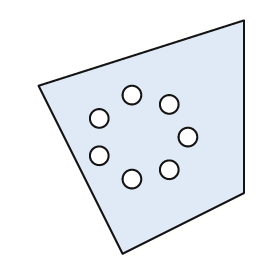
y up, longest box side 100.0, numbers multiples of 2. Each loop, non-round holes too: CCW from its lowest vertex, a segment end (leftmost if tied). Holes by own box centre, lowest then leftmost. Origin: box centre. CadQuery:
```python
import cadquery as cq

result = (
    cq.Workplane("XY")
    .moveTo(-8.0, -50.0)
    .lineTo(44.0, -24.0)
    .lineTo(44.0, 50.0)
    .lineTo(-44.0, 22.0)
    .close()
    .moveTo(-4.0, -18.0)
    .circle(4.0)
    .moveTo(12.0, -14.0)
    .circle(4.0)
    .moveTo(-18.0, -8.0)
    .circle(4.0)
    .moveTo(20.0, 0.0)
    .circle(4.0)
    .moveTo(-18.0, 8.0)
    .circle(4.0)
    .moveTo(12.0, 14.0)
    .circle(4.0)
    .moveTo(-4.0, 18.0)
    .circle(4.0)
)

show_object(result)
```